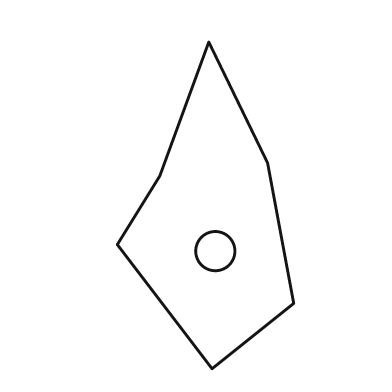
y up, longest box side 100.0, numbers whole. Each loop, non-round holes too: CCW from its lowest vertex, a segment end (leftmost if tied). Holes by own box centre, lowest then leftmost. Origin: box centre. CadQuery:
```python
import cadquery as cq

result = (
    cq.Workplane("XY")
    .moveTo(2.0, -50.0)
    .lineTo(27.0, -30.0)
    .lineTo(19.0, 13.0)
    .lineTo(1.0, 50.0)
    .lineTo(-14.0, 9.0)
    .lineTo(-27.0, -12.0)
    .close()
    .moveTo(3.0, -14.0)
    .circle(6.0)
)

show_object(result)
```